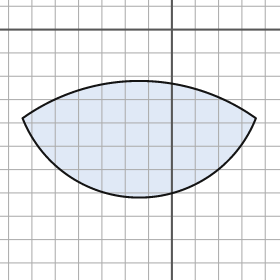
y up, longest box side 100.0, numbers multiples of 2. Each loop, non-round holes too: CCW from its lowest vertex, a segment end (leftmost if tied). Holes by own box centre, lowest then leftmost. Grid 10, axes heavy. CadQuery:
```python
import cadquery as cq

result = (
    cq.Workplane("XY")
    .moveTo(-64.0, -38.0)
    .threePointArc((-14.0, -72.0), (36.0, -38.0))
    .threePointArc((-14.0, -22.0), (-64.0, -38.0))
    .close()
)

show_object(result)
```